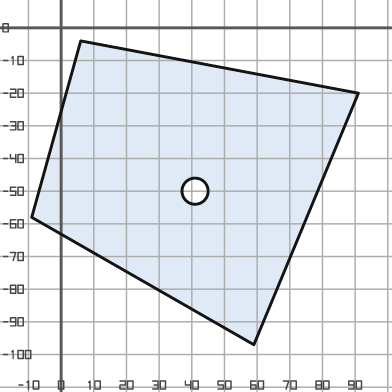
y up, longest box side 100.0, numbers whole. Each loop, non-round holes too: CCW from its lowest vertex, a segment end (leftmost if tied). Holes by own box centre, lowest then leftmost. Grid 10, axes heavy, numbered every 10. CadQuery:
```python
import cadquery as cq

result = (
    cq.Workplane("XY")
    .moveTo(59.0, -97.0)
    .lineTo(91.0, -20.0)
    .lineTo(6.0, -4.0)
    .lineTo(-9.0, -58.0)
    .close()
    .moveTo(41.0, -50.0)
    .circle(4.0)
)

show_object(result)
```